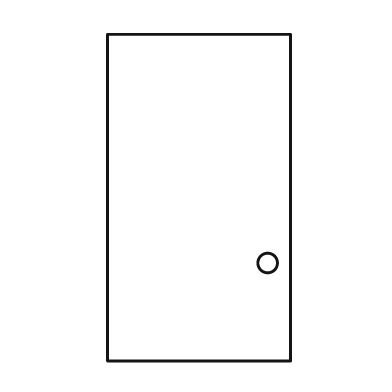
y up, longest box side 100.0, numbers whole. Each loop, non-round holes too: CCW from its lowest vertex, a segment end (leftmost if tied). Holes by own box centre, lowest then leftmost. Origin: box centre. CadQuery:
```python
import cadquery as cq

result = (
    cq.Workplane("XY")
    .moveTo(-28.0, -50.0)
    .lineTo(28.0, -50.0)
    .lineTo(28.0, 50.0)
    .lineTo(-28.0, 50.0)
    .close()
    .moveTo(21.0, -20.0)
    .circle(3.0)
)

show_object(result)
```